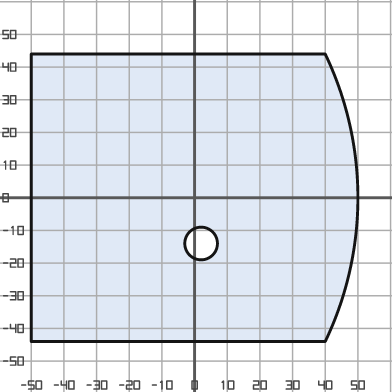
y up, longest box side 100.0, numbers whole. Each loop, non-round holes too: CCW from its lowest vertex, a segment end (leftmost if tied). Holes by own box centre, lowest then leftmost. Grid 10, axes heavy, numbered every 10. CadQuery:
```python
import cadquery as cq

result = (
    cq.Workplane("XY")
    .moveTo(-50.0, -44.0)
    .lineTo(40.0, -44.0)
    .threePointArc((50.0, 0.0), (40.0, 44.0))
    .lineTo(-50.0, 44.0)
    .close()
    .moveTo(2.0, -14.0)
    .circle(5.0)
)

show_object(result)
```